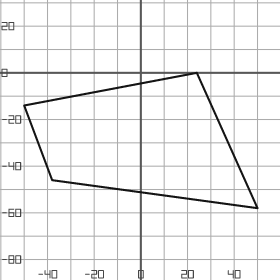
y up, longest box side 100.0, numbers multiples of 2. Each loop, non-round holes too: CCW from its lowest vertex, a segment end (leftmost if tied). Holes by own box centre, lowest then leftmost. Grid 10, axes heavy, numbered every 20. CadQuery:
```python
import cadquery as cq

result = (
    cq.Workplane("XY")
    .moveTo(50.0, -58.0)
    .lineTo(24.0, 0.0)
    .lineTo(-50.0, -14.0)
    .lineTo(-38.0, -46.0)
    .close()
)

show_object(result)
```